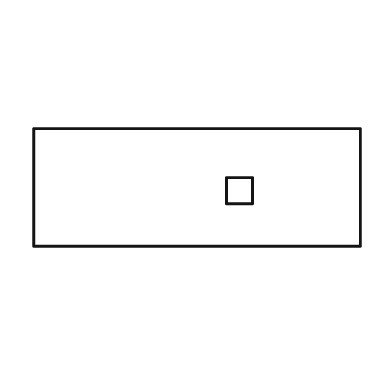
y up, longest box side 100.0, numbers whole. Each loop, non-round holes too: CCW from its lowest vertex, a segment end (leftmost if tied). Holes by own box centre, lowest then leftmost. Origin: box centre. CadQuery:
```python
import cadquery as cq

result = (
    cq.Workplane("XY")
    .moveTo(-50.0, -18.0)
    .lineTo(50.0, -18.0)
    .lineTo(50.0, 18.0)
    .lineTo(-50.0, 18.0)
    .close()
    .moveTo(9.0, -5.0)
    .lineTo(17.0, -5.0)
    .lineTo(17.0, 3.0)
    .lineTo(9.0, 3.0)
    .close()
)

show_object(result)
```